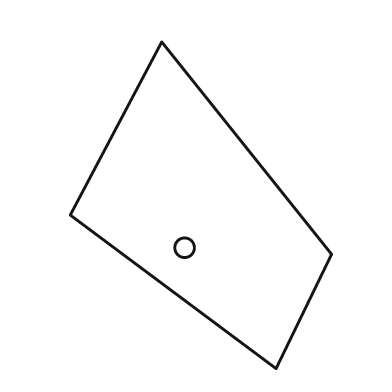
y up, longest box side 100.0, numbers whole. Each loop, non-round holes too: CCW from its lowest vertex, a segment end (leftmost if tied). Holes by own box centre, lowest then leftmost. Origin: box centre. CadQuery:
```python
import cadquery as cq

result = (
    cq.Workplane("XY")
    .moveTo(23.0, -50.0)
    .lineTo(40.0, -15.0)
    .lineTo(-12.0, 50.0)
    .lineTo(-40.0, -3.0)
    .close()
    .moveTo(-5.0, -13.0)
    .circle(3.0)
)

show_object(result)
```